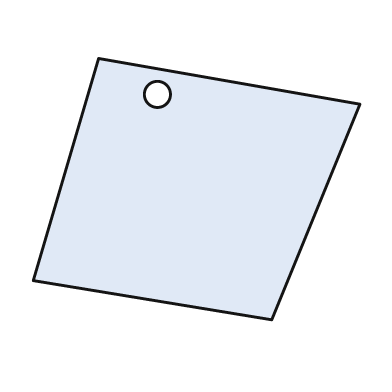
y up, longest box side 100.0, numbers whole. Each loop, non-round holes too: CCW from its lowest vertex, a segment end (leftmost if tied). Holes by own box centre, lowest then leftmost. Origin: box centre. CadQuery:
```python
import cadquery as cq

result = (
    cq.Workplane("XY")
    .moveTo(23.0, -40.0)
    .lineTo(50.0, 26.0)
    .lineTo(-30.0, 40.0)
    .lineTo(-50.0, -28.0)
    .close()
    .moveTo(-12.0, 29.0)
    .circle(4.0)
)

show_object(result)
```